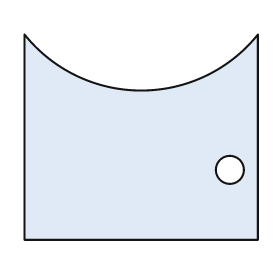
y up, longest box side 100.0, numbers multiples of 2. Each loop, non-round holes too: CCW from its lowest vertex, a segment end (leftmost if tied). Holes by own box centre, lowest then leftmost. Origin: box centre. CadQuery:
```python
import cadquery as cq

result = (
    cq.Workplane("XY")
    .moveTo(-50.0, -44.0)
    .lineTo(50.0, -44.0)
    .lineTo(50.0, 44.0)
    .threePointArc((0.0, 20.0), (-50.0, 44.0))
    .close()
    .moveTo(38.0, -14.0)
    .circle(6.0)
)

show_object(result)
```